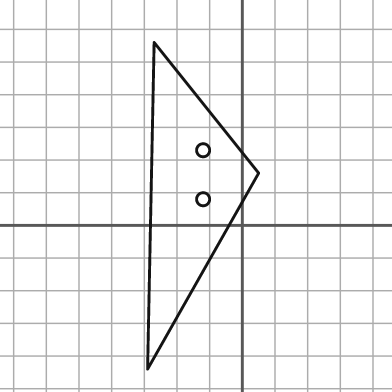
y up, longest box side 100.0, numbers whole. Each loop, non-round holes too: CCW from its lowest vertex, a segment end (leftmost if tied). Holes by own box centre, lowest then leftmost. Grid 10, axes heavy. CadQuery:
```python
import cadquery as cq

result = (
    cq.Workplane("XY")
    .moveTo(-29.0, -44.0)
    .lineTo(5.0, 16.0)
    .lineTo(-27.0, 56.0)
    .close()
    .moveTo(-12.0, 8.0)
    .circle(2.0)
    .moveTo(-12.0, 23.0)
    .circle(2.0)
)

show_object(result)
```